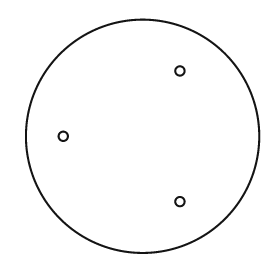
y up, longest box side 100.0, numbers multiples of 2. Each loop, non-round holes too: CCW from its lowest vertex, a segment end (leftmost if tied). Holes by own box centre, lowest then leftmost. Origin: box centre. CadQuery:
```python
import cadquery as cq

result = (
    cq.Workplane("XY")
    .moveTo(0.0, 0.0)
    .circle(50.0)
    .moveTo(16.0, -28.0)
    .circle(2.0)
    .moveTo(-34.0, 0.0)
    .circle(2.0)
    .moveTo(16.0, 28.0)
    .circle(2.0)
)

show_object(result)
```